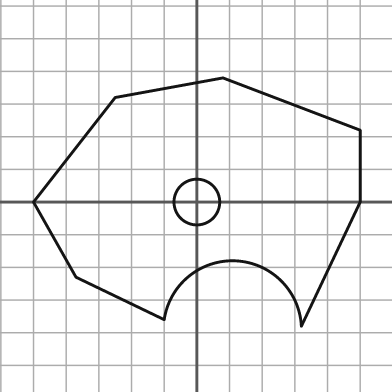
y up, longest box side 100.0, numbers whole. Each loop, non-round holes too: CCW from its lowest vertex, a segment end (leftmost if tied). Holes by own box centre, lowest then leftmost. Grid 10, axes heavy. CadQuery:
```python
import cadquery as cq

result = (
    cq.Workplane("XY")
    .moveTo(32.0, -38.0)
    .lineTo(50.0, 0.0)
    .lineTo(50.0, 22.0)
    .lineTo(8.0, 38.0)
    .lineTo(-25.0, 32.0)
    .lineTo(-50.0, 0.0)
    .lineTo(-37.0, -23.0)
    .lineTo(-10.0, -36.0)
    .threePointArc((12.0, -18.0), (32.0, -38.0))
    .close()
    .moveTo(0.0, 0.0)
    .circle(7.0)
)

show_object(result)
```